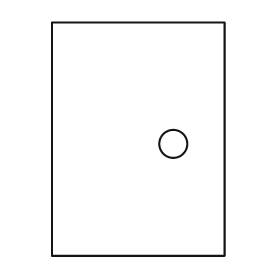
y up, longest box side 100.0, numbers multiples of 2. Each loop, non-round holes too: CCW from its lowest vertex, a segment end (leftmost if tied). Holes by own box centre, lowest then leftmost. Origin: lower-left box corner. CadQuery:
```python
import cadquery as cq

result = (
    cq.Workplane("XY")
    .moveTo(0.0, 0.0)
    .lineTo(74.0, 0.0)
    .lineTo(74.0, 100.0)
    .lineTo(0.0, 100.0)
    .close()
    .moveTo(52.0, 48.0)
    .circle(6.0)
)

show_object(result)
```